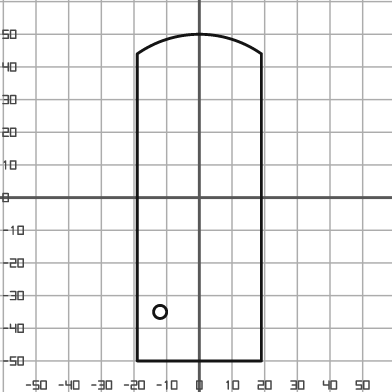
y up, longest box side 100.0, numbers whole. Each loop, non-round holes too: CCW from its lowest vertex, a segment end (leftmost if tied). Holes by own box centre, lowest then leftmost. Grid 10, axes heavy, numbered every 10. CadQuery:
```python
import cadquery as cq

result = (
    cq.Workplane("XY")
    .moveTo(-19.0, -50.0)
    .lineTo(19.0, -50.0)
    .lineTo(19.0, 44.0)
    .threePointArc((0.0, 50.0), (-19.0, 44.0))
    .close()
    .moveTo(-12.0, -35.0)
    .circle(2.0)
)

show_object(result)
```